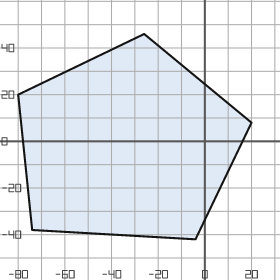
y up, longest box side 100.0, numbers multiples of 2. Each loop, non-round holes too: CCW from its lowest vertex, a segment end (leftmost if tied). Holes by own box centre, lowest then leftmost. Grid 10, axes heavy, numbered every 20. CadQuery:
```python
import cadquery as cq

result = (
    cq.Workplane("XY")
    .moveTo(-4.0, -42.0)
    .lineTo(20.0, 8.0)
    .lineTo(-26.0, 46.0)
    .lineTo(-80.0, 20.0)
    .lineTo(-74.0, -38.0)
    .close()
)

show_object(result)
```